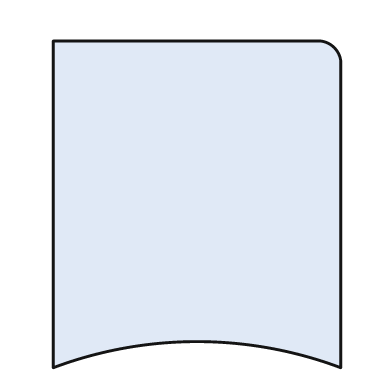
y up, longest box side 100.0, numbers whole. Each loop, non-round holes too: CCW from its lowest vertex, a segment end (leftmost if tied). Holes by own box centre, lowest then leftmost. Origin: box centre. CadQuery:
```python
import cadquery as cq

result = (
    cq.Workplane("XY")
    .moveTo(-44.0, -50.0)
    .threePointArc((0.0, -42.0), (44.0, -50.0))
    .lineTo(44.0, 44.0)
    .threePointArc((42.0, 48.0), (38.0, 50.0))
    .lineTo(-44.0, 50.0)
    .close()
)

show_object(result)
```